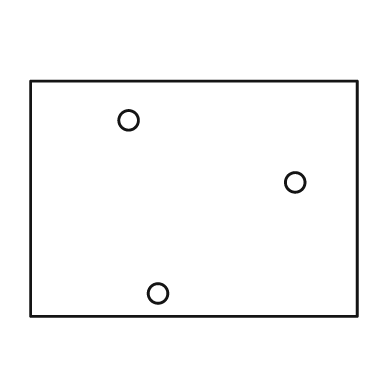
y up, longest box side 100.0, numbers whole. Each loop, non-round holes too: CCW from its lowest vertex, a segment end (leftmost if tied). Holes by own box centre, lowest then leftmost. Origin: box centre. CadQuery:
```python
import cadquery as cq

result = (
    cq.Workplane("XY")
    .moveTo(-50.0, -36.0)
    .lineTo(50.0, -36.0)
    .lineTo(50.0, 36.0)
    .lineTo(-50.0, 36.0)
    .close()
    .moveTo(-11.0, -29.0)
    .circle(3.0)
    .moveTo(31.0, 5.0)
    .circle(3.0)
    .moveTo(-20.0, 24.0)
    .circle(3.0)
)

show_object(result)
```